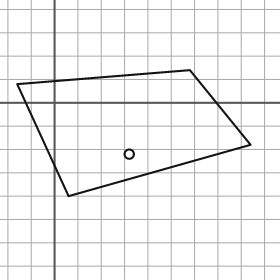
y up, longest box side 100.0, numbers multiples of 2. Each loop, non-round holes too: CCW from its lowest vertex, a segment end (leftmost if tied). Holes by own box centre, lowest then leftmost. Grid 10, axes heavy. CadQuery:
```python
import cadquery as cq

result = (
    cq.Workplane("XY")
    .moveTo(6.0, -40.0)
    .lineTo(84.0, -18.0)
    .lineTo(58.0, 14.0)
    .lineTo(-16.0, 8.0)
    .close()
    .moveTo(32.0, -22.0)
    .circle(2.0)
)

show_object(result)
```